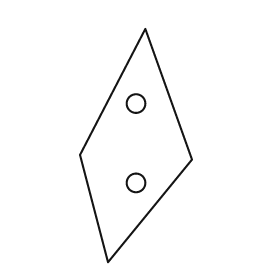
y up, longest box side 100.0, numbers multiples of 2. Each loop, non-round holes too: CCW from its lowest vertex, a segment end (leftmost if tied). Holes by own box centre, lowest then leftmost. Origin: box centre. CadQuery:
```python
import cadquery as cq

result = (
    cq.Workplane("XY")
    .moveTo(-12.0, -50.0)
    .lineTo(24.0, -6.0)
    .lineTo(4.0, 50.0)
    .lineTo(-24.0, -4.0)
    .close()
    .moveTo(0.0, -16.0)
    .circle(4.0)
    .moveTo(0.0, 18.0)
    .circle(4.0)
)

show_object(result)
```